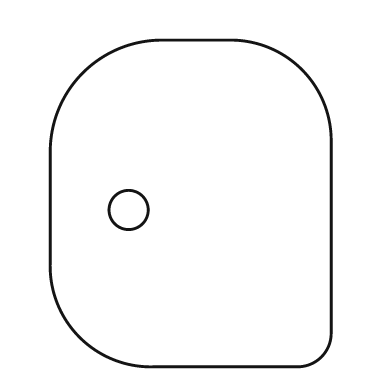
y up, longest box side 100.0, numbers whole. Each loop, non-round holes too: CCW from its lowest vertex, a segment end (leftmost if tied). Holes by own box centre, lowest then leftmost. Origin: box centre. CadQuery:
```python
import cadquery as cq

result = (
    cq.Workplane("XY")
    .moveTo(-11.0, -50.0)
    .lineTo(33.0, -50.0)
    .threePointArc((40.0, -47.0), (43.0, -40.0))
    .lineTo(43.0, 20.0)
    .threePointArc((34.0, 41.0), (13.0, 50.0))
    .lineTo(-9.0, 50.0)
    .threePointArc((-33.0, 40.0), (-43.0, 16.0))
    .lineTo(-43.0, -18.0)
    .threePointArc((-34.0, -41.0), (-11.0, -50.0))
    .close()
    .moveTo(-19.0, -2.0)
    .circle(6.0)
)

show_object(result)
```